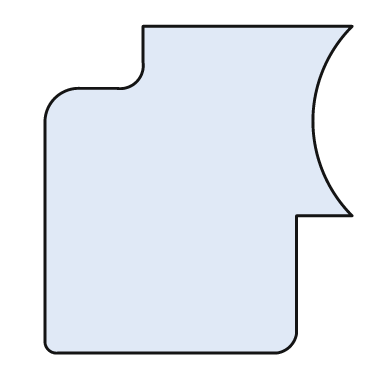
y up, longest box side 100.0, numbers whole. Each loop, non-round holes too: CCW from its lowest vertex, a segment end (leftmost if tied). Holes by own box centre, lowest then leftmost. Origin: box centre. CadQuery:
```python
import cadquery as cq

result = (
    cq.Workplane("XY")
    .moveTo(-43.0, -50.0)
    .lineTo(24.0, -50.0)
    .threePointArc((28.0, -48.0), (30.0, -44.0))
    .lineTo(30.0, -8.0)
    .lineTo(47.0, -8.0)
    .threePointArc((35.0, 21.0), (47.0, 50.0))
    .lineTo(-17.0, 50.0)
    .lineTo(-17.0, 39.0)
    .threePointArc((-19.0, 33.0), (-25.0, 31.0))
    .lineTo(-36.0, 31.0)
    .threePointArc((-44.0, 28.0), (-47.0, 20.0))
    .lineTo(-47.0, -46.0)
    .threePointArc((-46.0, -49.0), (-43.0, -50.0))
    .close()
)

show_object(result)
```